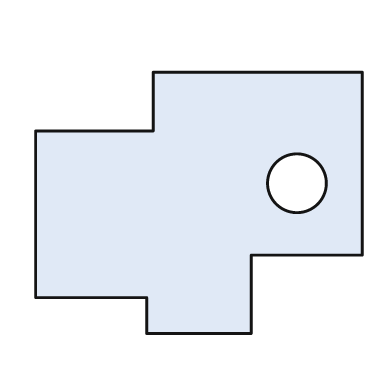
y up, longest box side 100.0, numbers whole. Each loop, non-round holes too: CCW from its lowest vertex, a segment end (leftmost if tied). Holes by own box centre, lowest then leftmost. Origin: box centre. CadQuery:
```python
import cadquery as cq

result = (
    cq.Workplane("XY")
    .moveTo(-16.0, -40.0)
    .lineTo(16.0, -40.0)
    .lineTo(16.0, -16.0)
    .lineTo(50.0, -16.0)
    .lineTo(50.0, 40.0)
    .lineTo(-14.0, 40.0)
    .lineTo(-14.0, 22.0)
    .lineTo(-50.0, 22.0)
    .lineTo(-50.0, -29.0)
    .lineTo(-16.0, -29.0)
    .close()
    .moveTo(30.0, 6.0)
    .circle(9.0)
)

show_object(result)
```